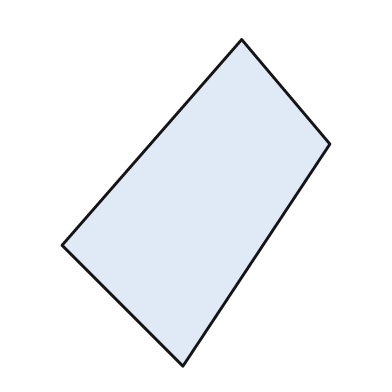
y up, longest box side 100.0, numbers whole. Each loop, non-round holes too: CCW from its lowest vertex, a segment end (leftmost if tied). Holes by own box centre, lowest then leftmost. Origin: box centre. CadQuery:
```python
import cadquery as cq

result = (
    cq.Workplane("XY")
    .moveTo(-4.0, -50.0)
    .lineTo(41.0, 18.0)
    .lineTo(14.0, 50.0)
    .lineTo(-41.0, -13.0)
    .close()
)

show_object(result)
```